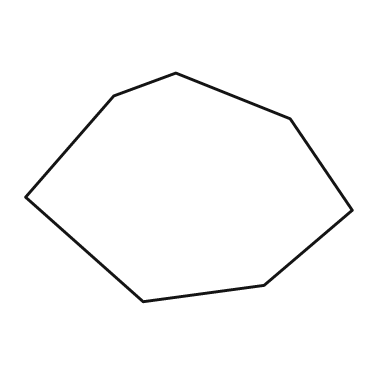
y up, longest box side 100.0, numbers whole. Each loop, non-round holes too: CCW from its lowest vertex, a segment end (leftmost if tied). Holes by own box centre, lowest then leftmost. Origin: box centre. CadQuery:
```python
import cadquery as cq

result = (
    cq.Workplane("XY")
    .moveTo(-14.0, -35.0)
    .lineTo(23.0, -30.0)
    .lineTo(50.0, -7.0)
    .lineTo(31.0, 21.0)
    .lineTo(-4.0, 35.0)
    .lineTo(-23.0, 28.0)
    .lineTo(-50.0, -3.0)
    .close()
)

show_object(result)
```